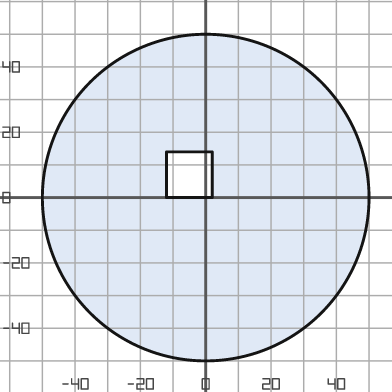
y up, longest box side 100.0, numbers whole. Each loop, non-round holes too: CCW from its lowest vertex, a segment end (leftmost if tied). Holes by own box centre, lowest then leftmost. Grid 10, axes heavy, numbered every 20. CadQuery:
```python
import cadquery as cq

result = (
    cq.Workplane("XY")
    .moveTo(0.0, 0.0)
    .circle(50.0)
    .moveTo(-12.0, 0.0)
    .lineTo(2.0, 0.0)
    .lineTo(2.0, 14.0)
    .lineTo(-12.0, 14.0)
    .close()
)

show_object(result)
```